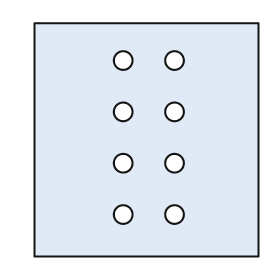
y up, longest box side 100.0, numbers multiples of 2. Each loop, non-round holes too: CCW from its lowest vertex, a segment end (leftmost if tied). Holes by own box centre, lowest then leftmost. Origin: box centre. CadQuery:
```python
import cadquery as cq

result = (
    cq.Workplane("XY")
    .moveTo(-48.0, -50.0)
    .lineTo(48.0, -50.0)
    .lineTo(48.0, 50.0)
    .lineTo(-48.0, 50.0)
    .close()
    .moveTo(-10.0, -32.0)
    .circle(4.0)
    .moveTo(12.0, -32.0)
    .circle(4.0)
    .moveTo(-10.0, -10.0)
    .circle(4.0)
    .moveTo(12.0, -10.0)
    .circle(4.0)
    .moveTo(-10.0, 12.0)
    .circle(4.0)
    .moveTo(12.0, 12.0)
    .circle(4.0)
    .moveTo(-10.0, 34.0)
    .circle(4.0)
    .moveTo(12.0, 34.0)
    .circle(4.0)
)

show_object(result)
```